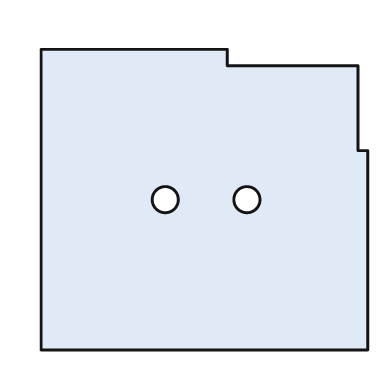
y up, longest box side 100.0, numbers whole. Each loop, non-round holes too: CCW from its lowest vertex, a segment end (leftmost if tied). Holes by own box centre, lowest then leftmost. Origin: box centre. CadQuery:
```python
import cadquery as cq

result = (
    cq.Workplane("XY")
    .moveTo(-50.0, -46.0)
    .lineTo(50.0, -46.0)
    .lineTo(50.0, 15.0)
    .lineTo(47.0, 15.0)
    .lineTo(47.0, 41.0)
    .lineTo(7.0, 41.0)
    .lineTo(7.0, 46.0)
    .lineTo(-50.0, 46.0)
    .close()
    .moveTo(-12.0, 0.0)
    .circle(4.0)
    .moveTo(13.0, 0.0)
    .circle(4.0)
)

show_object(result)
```